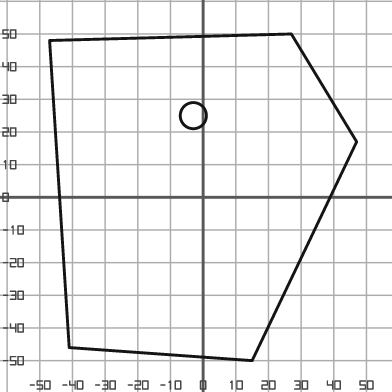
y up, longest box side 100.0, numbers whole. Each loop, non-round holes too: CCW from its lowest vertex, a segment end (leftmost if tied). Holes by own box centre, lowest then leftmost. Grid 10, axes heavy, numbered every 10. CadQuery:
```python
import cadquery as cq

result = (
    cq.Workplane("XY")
    .moveTo(15.0, -50.0)
    .lineTo(47.0, 17.0)
    .lineTo(27.0, 50.0)
    .lineTo(-47.0, 48.0)
    .lineTo(-41.0, -46.0)
    .close()
    .moveTo(-3.0, 25.0)
    .circle(4.0)
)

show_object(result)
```